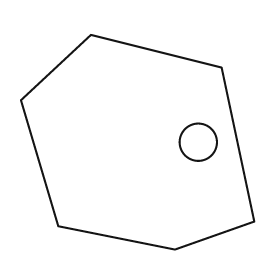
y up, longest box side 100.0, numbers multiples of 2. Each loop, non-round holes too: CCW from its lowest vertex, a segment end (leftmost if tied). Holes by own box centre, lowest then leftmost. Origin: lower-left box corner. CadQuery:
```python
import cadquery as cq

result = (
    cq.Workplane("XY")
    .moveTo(66.0, 0.0)
    .lineTo(100.0, 12.0)
    .lineTo(86.0, 78.0)
    .lineTo(30.0, 92.0)
    .lineTo(0.0, 64.0)
    .lineTo(16.0, 10.0)
    .close()
    .moveTo(76.0, 46.0)
    .circle(8.0)
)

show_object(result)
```